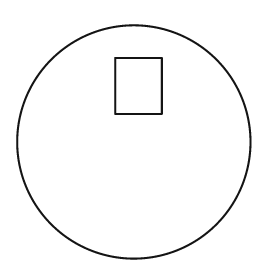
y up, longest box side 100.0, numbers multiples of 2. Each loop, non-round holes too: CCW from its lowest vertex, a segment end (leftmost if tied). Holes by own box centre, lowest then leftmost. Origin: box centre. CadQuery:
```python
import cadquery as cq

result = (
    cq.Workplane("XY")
    .moveTo(0.0, 0.0)
    .circle(50.0)
    .moveTo(-8.0, 12.0)
    .lineTo(12.0, 12.0)
    .lineTo(12.0, 36.0)
    .lineTo(-8.0, 36.0)
    .close()
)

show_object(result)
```